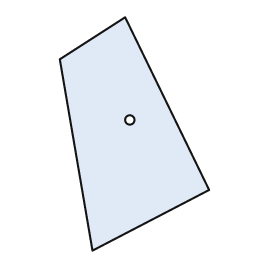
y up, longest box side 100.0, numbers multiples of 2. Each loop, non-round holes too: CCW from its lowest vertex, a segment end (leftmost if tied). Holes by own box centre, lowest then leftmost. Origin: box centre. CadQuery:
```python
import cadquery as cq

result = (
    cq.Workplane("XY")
    .moveTo(-18.0, -50.0)
    .lineTo(32.0, -24.0)
    .lineTo(-4.0, 50.0)
    .lineTo(-32.0, 32.0)
    .close()
    .moveTo(-2.0, 6.0)
    .circle(2.0)
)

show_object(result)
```